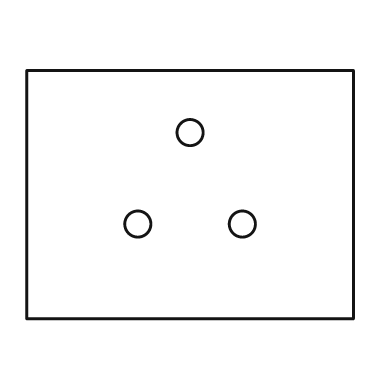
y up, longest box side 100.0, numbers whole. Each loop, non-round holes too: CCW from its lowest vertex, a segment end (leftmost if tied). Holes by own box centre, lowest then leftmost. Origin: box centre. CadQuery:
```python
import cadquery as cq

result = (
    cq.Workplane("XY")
    .moveTo(-50.0, -38.0)
    .lineTo(50.0, -38.0)
    .lineTo(50.0, 38.0)
    .lineTo(-50.0, 38.0)
    .close()
    .moveTo(-16.0, -9.0)
    .circle(4.0)
    .moveTo(16.0, -9.0)
    .circle(4.0)
    .moveTo(0.0, 19.0)
    .circle(4.0)
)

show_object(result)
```